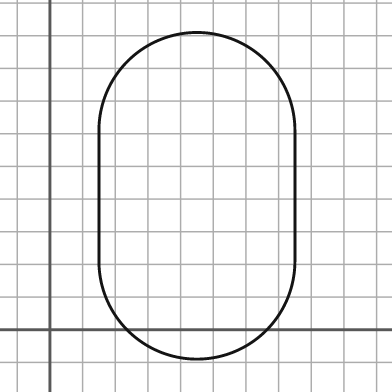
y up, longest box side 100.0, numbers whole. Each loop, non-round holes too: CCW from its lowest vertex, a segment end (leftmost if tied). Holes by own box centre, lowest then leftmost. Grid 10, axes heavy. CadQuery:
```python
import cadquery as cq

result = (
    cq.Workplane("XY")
    .moveTo(15.0, 21.0)
    .threePointArc((45.0, -9.0), (75.0, 21.0))
    .lineTo(75.0, 61.0)
    .threePointArc((45.0, 91.0), (15.0, 61.0))
    .close()
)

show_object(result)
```